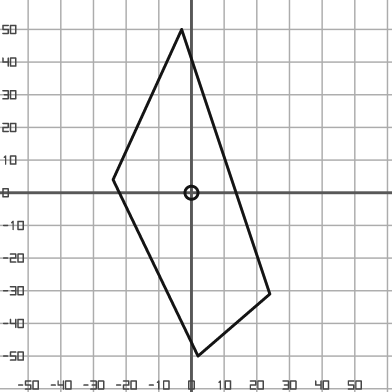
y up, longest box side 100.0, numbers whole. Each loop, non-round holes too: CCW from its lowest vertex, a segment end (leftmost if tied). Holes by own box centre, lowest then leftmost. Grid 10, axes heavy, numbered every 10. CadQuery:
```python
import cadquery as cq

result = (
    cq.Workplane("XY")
    .moveTo(2.0, -50.0)
    .lineTo(24.0, -31.0)
    .lineTo(-3.0, 50.0)
    .lineTo(-24.0, 4.0)
    .close()
    .moveTo(0.0, 0.0)
    .circle(2.0)
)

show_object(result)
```